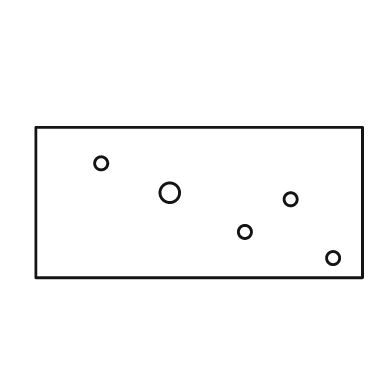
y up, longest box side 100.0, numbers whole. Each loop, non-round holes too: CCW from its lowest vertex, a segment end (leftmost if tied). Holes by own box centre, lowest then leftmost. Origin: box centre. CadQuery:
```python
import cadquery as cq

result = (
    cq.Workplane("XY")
    .moveTo(-50.0, -23.0)
    .lineTo(50.0, -23.0)
    .lineTo(50.0, 23.0)
    .lineTo(-50.0, 23.0)
    .close()
    .moveTo(41.0, -17.0)
    .circle(2.0)
    .moveTo(14.0, -9.0)
    .circle(2.0)
    .moveTo(28.0, 1.0)
    .circle(2.0)
    .moveTo(-9.0, 3.0)
    .circle(3.0)
    .moveTo(-30.0, 12.0)
    .circle(2.0)
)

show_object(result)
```